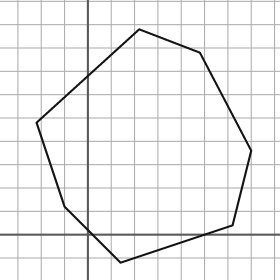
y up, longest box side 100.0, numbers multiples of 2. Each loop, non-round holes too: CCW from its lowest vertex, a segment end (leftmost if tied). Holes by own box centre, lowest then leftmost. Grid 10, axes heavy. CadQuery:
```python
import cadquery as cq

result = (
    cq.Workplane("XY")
    .moveTo(14.0, -12.0)
    .lineTo(62.0, 4.0)
    .lineTo(70.0, 36.0)
    .lineTo(48.0, 78.0)
    .lineTo(22.0, 88.0)
    .lineTo(-22.0, 48.0)
    .lineTo(-10.0, 12.0)
    .close()
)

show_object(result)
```